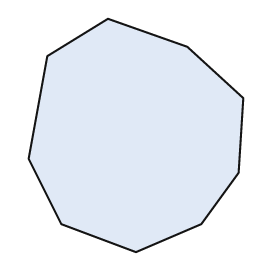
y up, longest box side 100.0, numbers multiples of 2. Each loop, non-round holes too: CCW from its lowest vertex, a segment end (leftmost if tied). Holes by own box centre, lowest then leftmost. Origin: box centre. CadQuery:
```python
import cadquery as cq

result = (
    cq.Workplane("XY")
    .moveTo(0.0, -50.0)
    .lineTo(28.0, -38.0)
    .lineTo(44.0, -16.0)
    .lineTo(46.0, 16.0)
    .lineTo(22.0, 38.0)
    .lineTo(-12.0, 50.0)
    .lineTo(-38.0, 34.0)
    .lineTo(-46.0, -10.0)
    .lineTo(-32.0, -38.0)
    .close()
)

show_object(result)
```